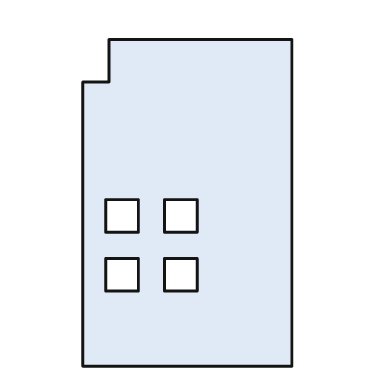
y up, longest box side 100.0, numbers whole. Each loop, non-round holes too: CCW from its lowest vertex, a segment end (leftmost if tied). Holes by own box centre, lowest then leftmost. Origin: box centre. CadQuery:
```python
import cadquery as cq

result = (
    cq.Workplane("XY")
    .moveTo(-32.0, -50.0)
    .lineTo(32.0, -50.0)
    .lineTo(32.0, 50.0)
    .lineTo(-24.0, 50.0)
    .lineTo(-24.0, 37.0)
    .lineTo(-32.0, 37.0)
    .close()
    .moveTo(-25.0, -27.0)
    .lineTo(-15.0, -27.0)
    .lineTo(-15.0, -17.0)
    .lineTo(-25.0, -17.0)
    .close()
    .moveTo(-7.0, -27.0)
    .lineTo(3.0, -27.0)
    .lineTo(3.0, -17.0)
    .lineTo(-7.0, -17.0)
    .close()
    .moveTo(-25.0, -9.0)
    .lineTo(-15.0, -9.0)
    .lineTo(-15.0, 1.0)
    .lineTo(-25.0, 1.0)
    .close()
    .moveTo(-7.0, -9.0)
    .lineTo(3.0, -9.0)
    .lineTo(3.0, 1.0)
    .lineTo(-7.0, 1.0)
    .close()
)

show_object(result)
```